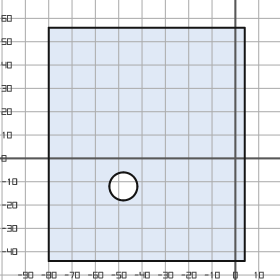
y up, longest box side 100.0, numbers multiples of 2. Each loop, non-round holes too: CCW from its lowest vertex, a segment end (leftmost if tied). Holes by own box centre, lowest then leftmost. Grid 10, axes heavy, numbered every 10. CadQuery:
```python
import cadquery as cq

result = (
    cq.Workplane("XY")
    .moveTo(-80.0, -44.0)
    .lineTo(4.0, -44.0)
    .lineTo(4.0, 56.0)
    .lineTo(-80.0, 56.0)
    .close()
    .moveTo(-48.0, -12.0)
    .circle(6.0)
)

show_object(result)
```